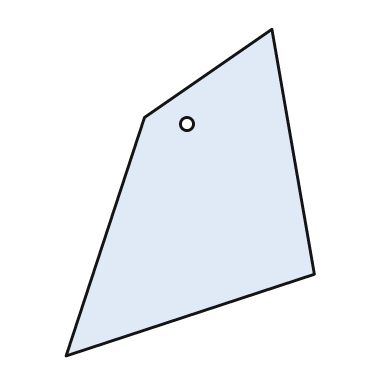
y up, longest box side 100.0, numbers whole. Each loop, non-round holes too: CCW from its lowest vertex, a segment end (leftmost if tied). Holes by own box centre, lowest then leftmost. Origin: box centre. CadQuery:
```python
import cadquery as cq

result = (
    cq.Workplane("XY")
    .moveTo(-38.0, -50.0)
    .lineTo(38.0, -25.0)
    .lineTo(25.0, 50.0)
    .lineTo(-14.0, 23.0)
    .close()
    .moveTo(-1.0, 21.0)
    .circle(2.0)
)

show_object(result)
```